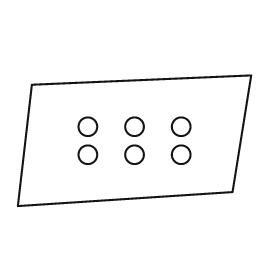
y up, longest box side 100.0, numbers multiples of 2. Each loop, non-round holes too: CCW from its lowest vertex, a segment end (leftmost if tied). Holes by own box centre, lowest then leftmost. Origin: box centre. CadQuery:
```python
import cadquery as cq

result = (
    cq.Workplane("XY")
    .moveTo(-50.0, -28.0)
    .lineTo(42.0, -22.0)
    .lineTo(50.0, 28.0)
    .lineTo(-44.0, 24.0)
    .close()
    .moveTo(-20.0, -6.0)
    .circle(4.0)
    .moveTo(0.0, -6.0)
    .circle(4.0)
    .moveTo(20.0, -6.0)
    .circle(4.0)
    .moveTo(-20.0, 6.0)
    .circle(4.0)
    .moveTo(0.0, 6.0)
    .circle(4.0)
    .moveTo(20.0, 6.0)
    .circle(4.0)
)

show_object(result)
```